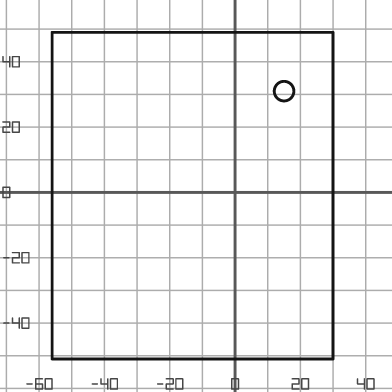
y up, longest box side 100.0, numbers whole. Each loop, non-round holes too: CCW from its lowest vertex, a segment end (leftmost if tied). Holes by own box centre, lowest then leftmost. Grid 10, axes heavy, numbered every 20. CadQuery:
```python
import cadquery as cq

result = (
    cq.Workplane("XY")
    .moveTo(-56.0, -51.0)
    .lineTo(30.0, -51.0)
    .lineTo(30.0, 49.0)
    .lineTo(-56.0, 49.0)
    .close()
    .moveTo(15.0, 31.0)
    .circle(3.0)
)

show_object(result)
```